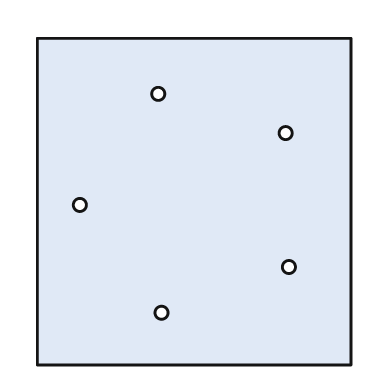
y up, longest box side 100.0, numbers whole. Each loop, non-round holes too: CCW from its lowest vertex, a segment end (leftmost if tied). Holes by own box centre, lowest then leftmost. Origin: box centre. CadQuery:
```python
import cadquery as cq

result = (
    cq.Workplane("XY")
    .moveTo(-48.0, -50.0)
    .lineTo(48.0, -50.0)
    .lineTo(48.0, 50.0)
    .lineTo(-48.0, 50.0)
    .close()
    .moveTo(-10.0, -34.0)
    .circle(2.0)
    .moveTo(29.0, -20.0)
    .circle(2.0)
    .moveTo(-35.0, -1.0)
    .circle(2.0)
    .moveTo(28.0, 21.0)
    .circle(2.0)
    .moveTo(-11.0, 33.0)
    .circle(2.0)
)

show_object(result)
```